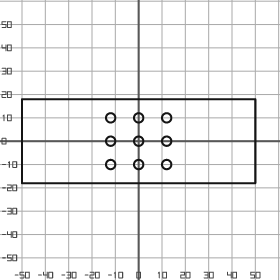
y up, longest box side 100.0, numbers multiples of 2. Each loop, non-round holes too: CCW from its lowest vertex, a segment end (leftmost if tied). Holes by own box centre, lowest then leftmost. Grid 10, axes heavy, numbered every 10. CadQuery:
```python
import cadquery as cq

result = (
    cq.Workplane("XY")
    .moveTo(-50.0, -18.0)
    .lineTo(50.0, -18.0)
    .lineTo(50.0, 18.0)
    .lineTo(-50.0, 18.0)
    .close()
    .moveTo(-12.0, -10.0)
    .circle(2.0)
    .moveTo(0.0, -10.0)
    .circle(2.0)
    .moveTo(12.0, -10.0)
    .circle(2.0)
    .moveTo(-12.0, 0.0)
    .circle(2.0)
    .moveTo(0.0, 0.0)
    .circle(2.0)
    .moveTo(12.0, 0.0)
    .circle(2.0)
    .moveTo(-12.0, 10.0)
    .circle(2.0)
    .moveTo(0.0, 10.0)
    .circle(2.0)
    .moveTo(12.0, 10.0)
    .circle(2.0)
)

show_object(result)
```